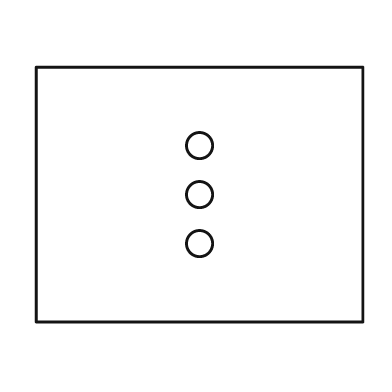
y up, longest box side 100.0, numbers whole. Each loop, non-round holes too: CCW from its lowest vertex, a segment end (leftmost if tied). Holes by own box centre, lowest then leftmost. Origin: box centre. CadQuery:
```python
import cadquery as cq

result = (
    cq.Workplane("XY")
    .moveTo(-50.0, -39.0)
    .lineTo(50.0, -39.0)
    .lineTo(50.0, 39.0)
    .lineTo(-50.0, 39.0)
    .close()
    .moveTo(0.0, -15.0)
    .circle(4.0)
    .moveTo(0.0, 0.0)
    .circle(4.0)
    .moveTo(0.0, 15.0)
    .circle(4.0)
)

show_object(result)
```